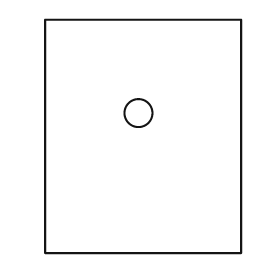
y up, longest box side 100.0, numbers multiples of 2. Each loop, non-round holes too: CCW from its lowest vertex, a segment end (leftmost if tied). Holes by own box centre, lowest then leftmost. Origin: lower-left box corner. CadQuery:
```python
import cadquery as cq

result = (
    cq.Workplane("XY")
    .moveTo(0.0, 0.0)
    .lineTo(84.0, 0.0)
    .lineTo(84.0, 100.0)
    .lineTo(0.0, 100.0)
    .close()
    .moveTo(40.0, 60.0)
    .circle(6.0)
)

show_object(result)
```